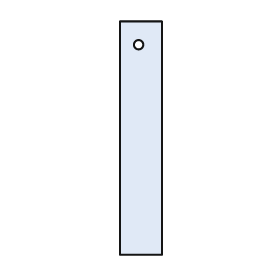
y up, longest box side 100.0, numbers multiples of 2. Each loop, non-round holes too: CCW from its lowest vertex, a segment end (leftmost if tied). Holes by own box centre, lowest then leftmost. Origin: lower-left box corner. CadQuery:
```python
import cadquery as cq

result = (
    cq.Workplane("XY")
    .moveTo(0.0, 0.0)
    .lineTo(18.0, 0.0)
    .lineTo(18.0, 100.0)
    .lineTo(0.0, 100.0)
    .close()
    .moveTo(8.0, 90.0)
    .circle(2.0)
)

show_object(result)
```